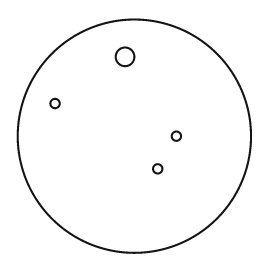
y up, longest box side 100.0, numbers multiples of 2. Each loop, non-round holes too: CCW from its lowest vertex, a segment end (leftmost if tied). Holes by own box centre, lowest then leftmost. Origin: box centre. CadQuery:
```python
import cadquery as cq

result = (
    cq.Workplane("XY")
    .moveTo(0.0, 0.0)
    .circle(50.0)
    .moveTo(10.0, -14.0)
    .circle(2.0)
    .moveTo(18.0, 0.0)
    .circle(2.0)
    .moveTo(-34.0, 14.0)
    .circle(2.0)
    .moveTo(-4.0, 34.0)
    .circle(4.0)
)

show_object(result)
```